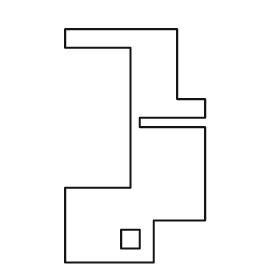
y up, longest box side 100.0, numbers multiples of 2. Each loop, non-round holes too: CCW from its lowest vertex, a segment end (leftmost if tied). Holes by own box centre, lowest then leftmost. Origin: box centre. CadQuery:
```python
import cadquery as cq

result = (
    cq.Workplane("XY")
    .moveTo(-30.0, -50.0)
    .lineTo(8.0, -50.0)
    .lineTo(8.0, -32.0)
    .lineTo(30.0, -32.0)
    .lineTo(30.0, 8.0)
    .lineTo(2.0, 8.0)
    .lineTo(2.0, 12.0)
    .lineTo(30.0, 12.0)
    .lineTo(30.0, 20.0)
    .lineTo(18.0, 20.0)
    .lineTo(18.0, 50.0)
    .lineTo(-30.0, 50.0)
    .lineTo(-30.0, 42.0)
    .lineTo(-2.0, 42.0)
    .lineTo(-2.0, -18.0)
    .lineTo(-30.0, -18.0)
    .close()
    .moveTo(-6.0, -44.0)
    .lineTo(2.0, -44.0)
    .lineTo(2.0, -36.0)
    .lineTo(-6.0, -36.0)
    .close()
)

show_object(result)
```